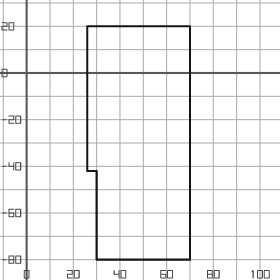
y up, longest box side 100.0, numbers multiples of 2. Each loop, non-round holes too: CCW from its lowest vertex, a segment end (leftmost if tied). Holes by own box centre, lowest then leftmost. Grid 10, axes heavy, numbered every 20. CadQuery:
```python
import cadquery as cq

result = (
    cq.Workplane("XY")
    .moveTo(30.0, -80.0)
    .lineTo(70.0, -80.0)
    .lineTo(70.0, 20.0)
    .lineTo(26.0, 20.0)
    .lineTo(26.0, -42.0)
    .lineTo(30.0, -42.0)
    .close()
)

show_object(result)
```